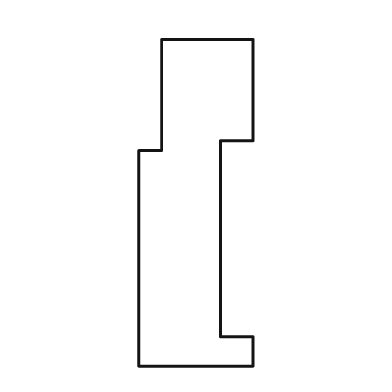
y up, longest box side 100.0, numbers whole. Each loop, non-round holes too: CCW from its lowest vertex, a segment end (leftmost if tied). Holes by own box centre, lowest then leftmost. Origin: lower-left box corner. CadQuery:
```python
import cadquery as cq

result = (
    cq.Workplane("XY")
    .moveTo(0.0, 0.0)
    .lineTo(35.0, 0.0)
    .lineTo(35.0, 9.0)
    .lineTo(25.0, 9.0)
    .lineTo(25.0, 69.0)
    .lineTo(35.0, 69.0)
    .lineTo(35.0, 100.0)
    .lineTo(7.0, 100.0)
    .lineTo(7.0, 66.0)
    .lineTo(0.0, 66.0)
    .close()
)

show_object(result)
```